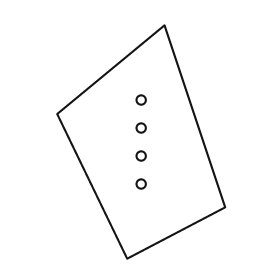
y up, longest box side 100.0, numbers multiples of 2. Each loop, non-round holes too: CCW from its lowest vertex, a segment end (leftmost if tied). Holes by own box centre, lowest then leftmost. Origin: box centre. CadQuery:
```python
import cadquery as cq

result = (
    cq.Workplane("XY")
    .moveTo(-6.0, -50.0)
    .lineTo(36.0, -28.0)
    .lineTo(10.0, 50.0)
    .lineTo(-36.0, 12.0)
    .close()
    .moveTo(0.0, -18.0)
    .circle(2.0)
    .moveTo(0.0, -6.0)
    .circle(2.0)
    .moveTo(0.0, 6.0)
    .circle(2.0)
    .moveTo(0.0, 18.0)
    .circle(2.0)
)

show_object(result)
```